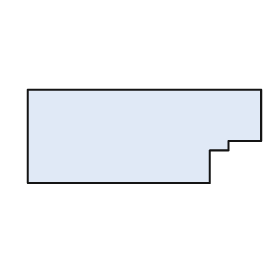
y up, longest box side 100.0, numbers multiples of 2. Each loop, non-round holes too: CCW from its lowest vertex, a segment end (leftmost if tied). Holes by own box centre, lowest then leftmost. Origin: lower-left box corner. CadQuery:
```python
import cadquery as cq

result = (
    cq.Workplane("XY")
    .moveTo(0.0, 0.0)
    .lineTo(78.0, 0.0)
    .lineTo(78.0, 14.0)
    .lineTo(86.0, 14.0)
    .lineTo(86.0, 18.0)
    .lineTo(100.0, 18.0)
    .lineTo(100.0, 40.0)
    .lineTo(0.0, 40.0)
    .close()
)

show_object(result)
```